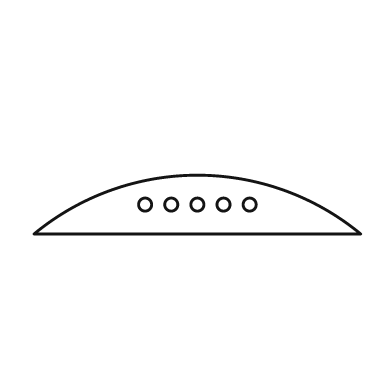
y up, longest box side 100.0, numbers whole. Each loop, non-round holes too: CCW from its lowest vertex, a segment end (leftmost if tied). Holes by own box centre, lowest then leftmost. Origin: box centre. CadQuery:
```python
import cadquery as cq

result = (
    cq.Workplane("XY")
    .moveTo(-50.0, -9.0)
    .lineTo(50.0, -9.0)
    .threePointArc((0.0, 9.0), (-50.0, -9.0))
    .close()
    .moveTo(-16.0, 0.0)
    .circle(2.0)
    .moveTo(-8.0, 0.0)
    .circle(2.0)
    .moveTo(0.0, 0.0)
    .circle(2.0)
    .moveTo(8.0, 0.0)
    .circle(2.0)
    .moveTo(16.0, 0.0)
    .circle(2.0)
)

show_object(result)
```